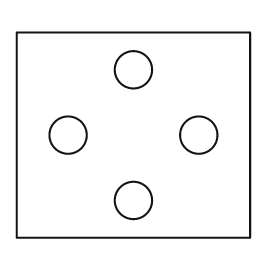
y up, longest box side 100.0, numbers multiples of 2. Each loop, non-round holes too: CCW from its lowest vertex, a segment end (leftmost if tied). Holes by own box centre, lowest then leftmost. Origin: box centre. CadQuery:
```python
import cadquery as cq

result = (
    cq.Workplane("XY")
    .moveTo(-50.0, -44.0)
    .lineTo(50.0, -44.0)
    .lineTo(50.0, 44.0)
    .lineTo(-50.0, 44.0)
    .close()
    .moveTo(0.0, -28.0)
    .circle(8.0)
    .moveTo(-28.0, 0.0)
    .circle(8.0)
    .moveTo(28.0, 0.0)
    .circle(8.0)
    .moveTo(0.0, 28.0)
    .circle(8.0)
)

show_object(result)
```